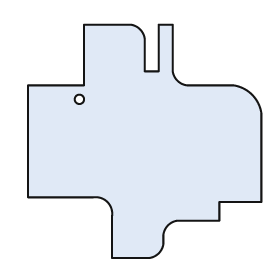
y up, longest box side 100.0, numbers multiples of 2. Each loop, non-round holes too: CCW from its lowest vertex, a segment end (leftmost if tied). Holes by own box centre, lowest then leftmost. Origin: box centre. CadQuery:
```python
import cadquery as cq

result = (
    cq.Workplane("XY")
    .moveTo(-14.0, -50.0)
    .lineTo(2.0, -50.0)
    .threePointArc((6.0, -48.0), (8.0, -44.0))
    .lineTo(8.0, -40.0)
    .threePointArc((10.0, -36.0), (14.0, -34.0))
    .lineTo(32.0, -34.0)
    .lineTo(32.0, -26.0)
    .lineTo(50.0, -26.0)
    .lineTo(50.0, 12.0)
    .threePointArc((46.0, 20.0), (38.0, 24.0))
    .lineTo(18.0, 24.0)
    .threePointArc((14.0, 26.0), (12.0, 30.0))
    .lineTo(12.0, 50.0)
    .lineTo(6.0, 50.0)
    .lineTo(6.0, 30.0)
    .lineTo(0.0, 30.0)
    .lineTo(0.0, 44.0)
    .threePointArc((-2.0, 48.0), (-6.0, 50.0))
    .lineTo(-26.0, 50.0)
    .lineTo(-26.0, 24.0)
    .lineTo(-50.0, 24.0)
    .lineTo(-50.0, -24.0)
    .lineTo(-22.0, -24.0)
    .threePointArc((-16.0, -26.0), (-14.0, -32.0))
    .close()
    .moveTo(-28.0, 18.0)
    .circle(2.0)
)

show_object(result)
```